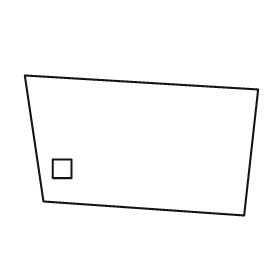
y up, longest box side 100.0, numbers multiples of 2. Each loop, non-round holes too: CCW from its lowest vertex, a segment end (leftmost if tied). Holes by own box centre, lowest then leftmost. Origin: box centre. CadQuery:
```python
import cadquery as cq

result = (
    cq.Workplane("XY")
    .moveTo(44.0, -30.0)
    .lineTo(50.0, 24.0)
    .lineTo(-50.0, 30.0)
    .lineTo(-42.0, -24.0)
    .close()
    .moveTo(-38.0, -14.0)
    .lineTo(-30.0, -14.0)
    .lineTo(-30.0, -6.0)
    .lineTo(-38.0, -6.0)
    .close()
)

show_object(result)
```